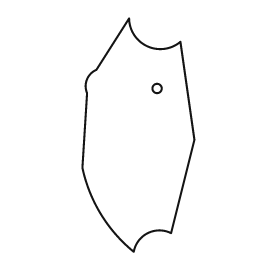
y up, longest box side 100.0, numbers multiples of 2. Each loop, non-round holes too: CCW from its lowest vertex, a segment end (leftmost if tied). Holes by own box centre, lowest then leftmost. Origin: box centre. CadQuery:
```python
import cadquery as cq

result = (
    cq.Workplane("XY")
    .moveTo(-2.0, -50.0)
    .threePointArc((4.0, -42.0), (14.0, -42.0))
    .lineTo(24.0, -2.0)
    .lineTo(18.0, 40.0)
    .threePointArc((4.0, 38.0), (-4.0, 50.0))
    .lineTo(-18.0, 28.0)
    .threePointArc((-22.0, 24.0), (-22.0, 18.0))
    .lineTo(-24.0, -14.0)
    .threePointArc((-16.0, -34.0), (-2.0, -50.0))
    .close()
    .moveTo(8.0, 20.0)
    .circle(2.0)
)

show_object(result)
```